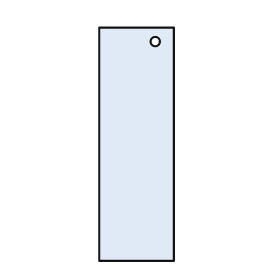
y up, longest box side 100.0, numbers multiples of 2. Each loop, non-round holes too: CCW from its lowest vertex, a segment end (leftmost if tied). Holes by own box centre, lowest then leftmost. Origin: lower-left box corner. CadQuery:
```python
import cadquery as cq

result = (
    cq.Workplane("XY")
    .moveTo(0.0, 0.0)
    .lineTo(32.0, 0.0)
    .lineTo(32.0, 100.0)
    .lineTo(0.0, 100.0)
    .close()
    .moveTo(24.0, 94.0)
    .circle(2.0)
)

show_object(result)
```